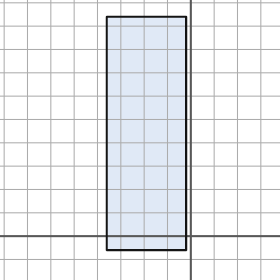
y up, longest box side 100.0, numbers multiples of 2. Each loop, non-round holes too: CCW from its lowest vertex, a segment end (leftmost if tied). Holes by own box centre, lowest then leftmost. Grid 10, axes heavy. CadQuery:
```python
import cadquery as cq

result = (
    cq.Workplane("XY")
    .moveTo(-36.0, -6.0)
    .lineTo(-2.0, -6.0)
    .lineTo(-2.0, 94.0)
    .lineTo(-36.0, 94.0)
    .close()
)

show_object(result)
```